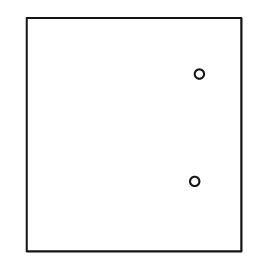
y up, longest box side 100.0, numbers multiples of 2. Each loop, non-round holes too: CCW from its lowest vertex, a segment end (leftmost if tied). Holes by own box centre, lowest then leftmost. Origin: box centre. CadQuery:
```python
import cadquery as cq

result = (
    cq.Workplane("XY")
    .moveTo(-46.0, -50.0)
    .lineTo(46.0, -50.0)
    .lineTo(46.0, 50.0)
    .lineTo(-46.0, 50.0)
    .close()
    .moveTo(26.0, -20.0)
    .circle(2.0)
    .moveTo(28.0, 26.0)
    .circle(2.0)
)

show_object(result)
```